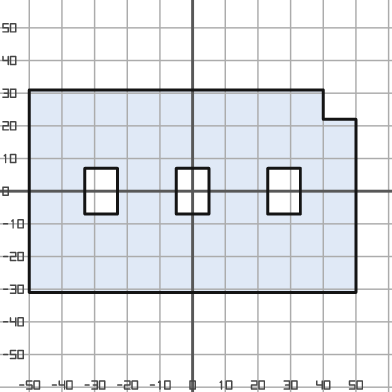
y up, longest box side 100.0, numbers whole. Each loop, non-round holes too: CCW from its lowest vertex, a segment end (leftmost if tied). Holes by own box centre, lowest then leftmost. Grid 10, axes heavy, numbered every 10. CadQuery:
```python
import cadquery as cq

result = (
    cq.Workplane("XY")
    .moveTo(-50.0, -31.0)
    .lineTo(50.0, -31.0)
    .lineTo(50.0, 22.0)
    .lineTo(40.0, 22.0)
    .lineTo(40.0, 31.0)
    .lineTo(-50.0, 31.0)
    .close()
    .moveTo(-33.0, -7.0)
    .lineTo(-23.0, -7.0)
    .lineTo(-23.0, 7.0)
    .lineTo(-33.0, 7.0)
    .close()
    .moveTo(-5.0, -7.0)
    .lineTo(5.0, -7.0)
    .lineTo(5.0, 7.0)
    .lineTo(-5.0, 7.0)
    .close()
    .moveTo(23.0, -7.0)
    .lineTo(33.0, -7.0)
    .lineTo(33.0, 7.0)
    .lineTo(23.0, 7.0)
    .close()
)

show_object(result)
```